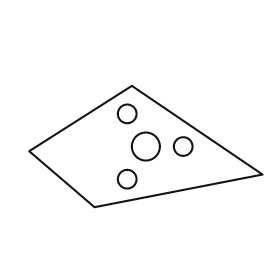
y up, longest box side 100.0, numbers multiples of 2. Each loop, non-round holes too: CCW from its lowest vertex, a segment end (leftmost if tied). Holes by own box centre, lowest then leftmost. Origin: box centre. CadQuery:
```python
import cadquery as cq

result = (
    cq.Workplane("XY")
    .moveTo(-22.0, -26.0)
    .lineTo(50.0, -12.0)
    .lineTo(-6.0, 26.0)
    .lineTo(-50.0, -2.0)
    .close()
    .moveTo(-8.0, -14.0)
    .circle(4.0)
    .moveTo(0.0, 0.0)
    .circle(6.0)
    .moveTo(16.0, 0.0)
    .circle(4.0)
    .moveTo(-8.0, 14.0)
    .circle(4.0)
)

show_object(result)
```